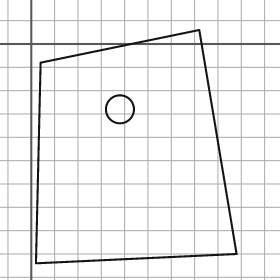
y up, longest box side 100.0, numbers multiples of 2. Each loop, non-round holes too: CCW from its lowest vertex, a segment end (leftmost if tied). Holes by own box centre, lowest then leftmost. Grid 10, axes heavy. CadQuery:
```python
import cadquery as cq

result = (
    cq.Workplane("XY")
    .moveTo(2.0, -94.0)
    .lineTo(88.0, -90.0)
    .lineTo(72.0, 6.0)
    .lineTo(4.0, -8.0)
    .close()
    .moveTo(38.0, -28.0)
    .circle(6.0)
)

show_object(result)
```